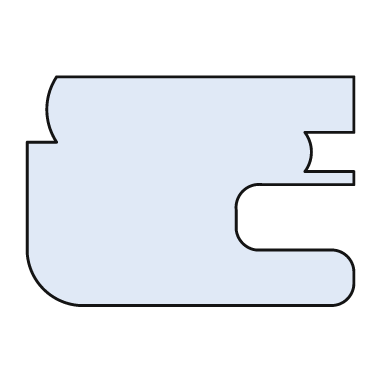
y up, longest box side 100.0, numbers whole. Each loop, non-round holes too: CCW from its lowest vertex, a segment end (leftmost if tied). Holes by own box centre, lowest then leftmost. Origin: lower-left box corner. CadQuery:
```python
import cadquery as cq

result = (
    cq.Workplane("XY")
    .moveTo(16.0, 0.0)
    .lineTo(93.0, 0.0)
    .threePointArc((98.0, 2.0), (100.0, 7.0))
    .lineTo(100.0, 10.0)
    .threePointArc((98.0, 15.0), (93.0, 17.0))
    .lineTo(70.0, 17.0)
    .threePointArc((66.0, 19.0), (64.0, 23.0))
    .lineTo(64.0, 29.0)
    .threePointArc((66.0, 35.0), (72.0, 37.0))
    .lineTo(100.0, 37.0)
    .lineTo(100.0, 41.0)
    .lineTo(85.0, 41.0)
    .threePointArc((87.0, 47.0), (85.0, 53.0))
    .lineTo(100.0, 53.0)
    .lineTo(100.0, 70.0)
    .lineTo(9.0, 70.0)
    .threePointArc((6.0, 60.0), (9.0, 50.0))
    .lineTo(0.0, 50.0)
    .lineTo(0.0, 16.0)
    .threePointArc((5.0, 5.0), (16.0, 0.0))
    .close()
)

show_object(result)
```